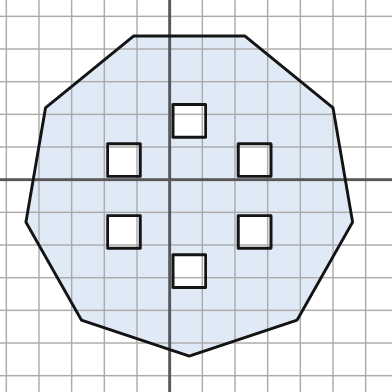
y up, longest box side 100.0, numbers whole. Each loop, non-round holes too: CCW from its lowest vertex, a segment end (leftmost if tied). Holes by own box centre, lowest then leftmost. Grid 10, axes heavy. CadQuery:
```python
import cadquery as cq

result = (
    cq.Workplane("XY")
    .moveTo(6.0, -54.0)
    .lineTo(39.0, -43.0)
    .lineTo(56.0, -13.0)
    .lineTo(50.0, 22.0)
    .lineTo(23.0, 44.0)
    .lineTo(-11.0, 44.0)
    .lineTo(-38.0, 22.0)
    .lineTo(-44.0, -13.0)
    .lineTo(-27.0, -43.0)
    .close()
    .moveTo(1.0, -33.0)
    .lineTo(11.0, -33.0)
    .lineTo(11.0, -23.0)
    .lineTo(1.0, -23.0)
    .close()
    .moveTo(-19.0, -21.0)
    .lineTo(-9.0, -21.0)
    .lineTo(-9.0, -11.0)
    .lineTo(-19.0, -11.0)
    .close()
    .moveTo(21.0, -21.0)
    .lineTo(31.0, -21.0)
    .lineTo(31.0, -11.0)
    .lineTo(21.0, -11.0)
    .close()
    .moveTo(-19.0, 1.0)
    .lineTo(-9.0, 1.0)
    .lineTo(-9.0, 11.0)
    .lineTo(-19.0, 11.0)
    .close()
    .moveTo(21.0, 1.0)
    .lineTo(31.0, 1.0)
    .lineTo(31.0, 11.0)
    .lineTo(21.0, 11.0)
    .close()
    .moveTo(1.0, 13.0)
    .lineTo(11.0, 13.0)
    .lineTo(11.0, 23.0)
    .lineTo(1.0, 23.0)
    .close()
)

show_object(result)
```